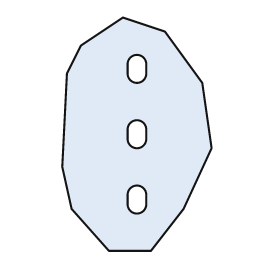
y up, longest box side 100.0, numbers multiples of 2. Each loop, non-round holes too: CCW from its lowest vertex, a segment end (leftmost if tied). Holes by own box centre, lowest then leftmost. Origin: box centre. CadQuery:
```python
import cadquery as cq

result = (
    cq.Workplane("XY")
    .moveTo(-12.0, -50.0)
    .lineTo(6.0, -50.0)
    .lineTo(20.0, -32.0)
    .lineTo(32.0, -6.0)
    .lineTo(28.0, 22.0)
    .lineTo(12.0, 44.0)
    .lineTo(-6.0, 50.0)
    .lineTo(-24.0, 38.0)
    .lineTo(-30.0, 26.0)
    .lineTo(-32.0, -14.0)
    .lineTo(-28.0, -32.0)
    .close()
    .moveTo(-4.0, -30.0)
    .threePointArc((0.0, -34.0), (4.0, -30.0))
    .lineTo(4.0, -26.0)
    .threePointArc((0.0, -22.0), (-4.0, -26.0))
    .close()
    .moveTo(-4.0, -2.0)
    .threePointArc((0.0, -6.0), (4.0, -2.0))
    .lineTo(4.0, 2.0)
    .threePointArc((0.0, 6.0), (-4.0, 2.0))
    .close()
    .moveTo(-4.0, 26.0)
    .threePointArc((0.0, 22.0), (4.0, 26.0))
    .lineTo(4.0, 30.0)
    .threePointArc((0.0, 34.0), (-4.0, 30.0))
    .close()
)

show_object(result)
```